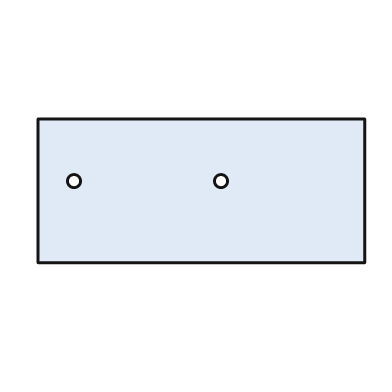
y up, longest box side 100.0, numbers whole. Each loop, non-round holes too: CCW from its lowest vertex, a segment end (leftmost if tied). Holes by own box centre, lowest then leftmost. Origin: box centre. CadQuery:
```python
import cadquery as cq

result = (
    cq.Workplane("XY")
    .moveTo(-50.0, -22.0)
    .lineTo(50.0, -22.0)
    .lineTo(50.0, 22.0)
    .lineTo(-50.0, 22.0)
    .close()
    .moveTo(-39.0, 3.0)
    .circle(2.0)
    .moveTo(6.0, 3.0)
    .circle(2.0)
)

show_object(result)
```